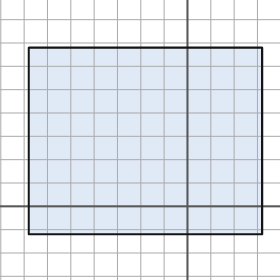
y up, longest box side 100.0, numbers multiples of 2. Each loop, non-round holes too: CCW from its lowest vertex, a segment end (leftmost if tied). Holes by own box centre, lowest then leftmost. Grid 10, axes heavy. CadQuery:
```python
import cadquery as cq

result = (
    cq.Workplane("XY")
    .moveTo(-68.0, -12.0)
    .lineTo(32.0, -12.0)
    .lineTo(32.0, 68.0)
    .lineTo(-68.0, 68.0)
    .close()
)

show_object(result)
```